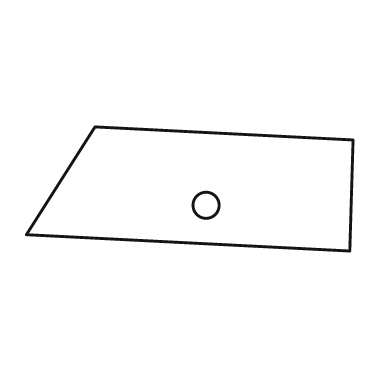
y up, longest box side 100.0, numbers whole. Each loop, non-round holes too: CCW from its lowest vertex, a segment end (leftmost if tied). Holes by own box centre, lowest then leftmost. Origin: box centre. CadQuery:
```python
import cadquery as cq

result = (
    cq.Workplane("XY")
    .moveTo(49.0, -19.0)
    .lineTo(50.0, 15.0)
    .lineTo(-29.0, 19.0)
    .lineTo(-50.0, -14.0)
    .close()
    .moveTo(5.0, -5.0)
    .circle(4.0)
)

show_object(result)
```